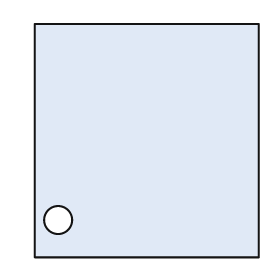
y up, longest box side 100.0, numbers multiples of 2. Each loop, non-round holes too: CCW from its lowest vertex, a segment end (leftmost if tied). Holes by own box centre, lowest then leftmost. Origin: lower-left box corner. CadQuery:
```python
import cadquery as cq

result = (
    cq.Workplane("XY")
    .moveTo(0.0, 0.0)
    .lineTo(96.0, 0.0)
    .lineTo(96.0, 100.0)
    .lineTo(0.0, 100.0)
    .close()
    .moveTo(10.0, 16.0)
    .circle(6.0)
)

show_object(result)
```